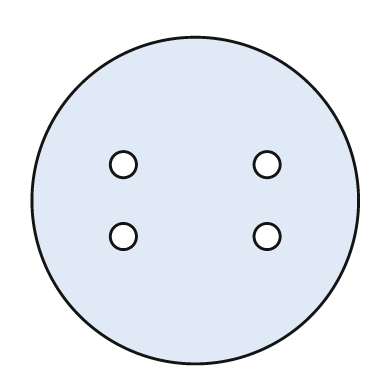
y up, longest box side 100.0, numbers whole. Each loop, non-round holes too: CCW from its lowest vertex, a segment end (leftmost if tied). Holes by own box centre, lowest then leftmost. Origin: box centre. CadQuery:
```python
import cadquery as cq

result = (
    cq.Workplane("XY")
    .moveTo(0.0, 0.0)
    .circle(50.0)
    .moveTo(-22.0, -11.0)
    .circle(4.0)
    .moveTo(22.0, -11.0)
    .circle(4.0)
    .moveTo(-22.0, 11.0)
    .circle(4.0)
    .moveTo(22.0, 11.0)
    .circle(4.0)
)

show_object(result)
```